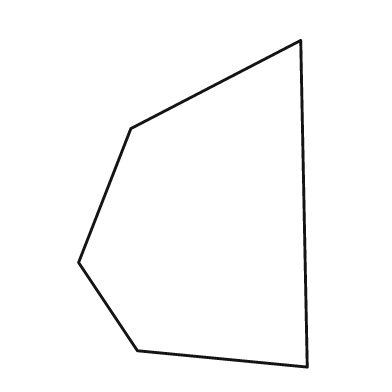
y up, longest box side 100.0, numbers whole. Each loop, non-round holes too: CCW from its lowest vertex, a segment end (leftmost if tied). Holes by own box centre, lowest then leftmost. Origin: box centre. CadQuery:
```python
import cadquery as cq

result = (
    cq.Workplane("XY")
    .moveTo(35.0, -50.0)
    .lineTo(33.0, 50.0)
    .lineTo(-19.0, 23.0)
    .lineTo(-35.0, -18.0)
    .lineTo(-17.0, -45.0)
    .close()
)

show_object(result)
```